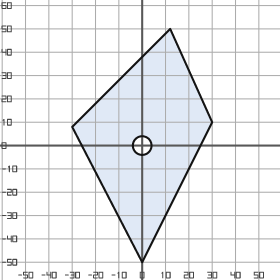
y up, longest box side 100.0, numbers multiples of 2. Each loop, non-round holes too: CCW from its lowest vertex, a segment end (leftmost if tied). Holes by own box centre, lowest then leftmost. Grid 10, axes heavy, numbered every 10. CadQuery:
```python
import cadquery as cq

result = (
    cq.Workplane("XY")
    .moveTo(0.0, -50.0)
    .lineTo(30.0, 10.0)
    .lineTo(12.0, 50.0)
    .lineTo(-30.0, 8.0)
    .close()
    .moveTo(0.0, 0.0)
    .circle(4.0)
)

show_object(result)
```